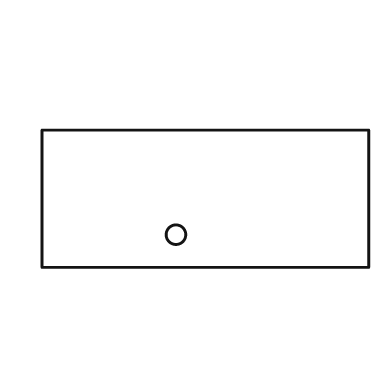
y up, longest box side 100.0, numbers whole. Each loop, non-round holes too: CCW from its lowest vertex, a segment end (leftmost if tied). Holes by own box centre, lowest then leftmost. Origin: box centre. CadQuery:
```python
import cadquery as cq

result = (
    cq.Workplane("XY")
    .moveTo(-50.0, -21.0)
    .lineTo(50.0, -21.0)
    .lineTo(50.0, 21.0)
    .lineTo(-50.0, 21.0)
    .close()
    .moveTo(-9.0, -11.0)
    .circle(3.0)
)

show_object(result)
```